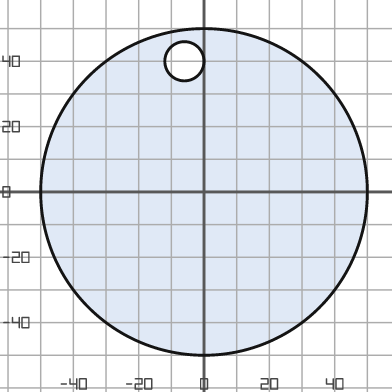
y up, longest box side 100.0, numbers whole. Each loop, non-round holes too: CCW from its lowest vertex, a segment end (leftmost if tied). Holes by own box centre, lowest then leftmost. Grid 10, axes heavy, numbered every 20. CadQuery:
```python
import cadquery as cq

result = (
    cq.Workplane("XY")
    .moveTo(0.0, 0.0)
    .circle(50.0)
    .moveTo(-6.0, 40.0)
    .circle(6.0)
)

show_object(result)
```